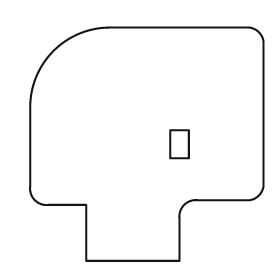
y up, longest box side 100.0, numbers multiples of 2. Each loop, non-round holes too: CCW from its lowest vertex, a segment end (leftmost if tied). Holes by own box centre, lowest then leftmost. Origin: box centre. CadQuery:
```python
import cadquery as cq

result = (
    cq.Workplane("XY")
    .moveTo(-26.0, -50.0)
    .lineTo(14.0, -50.0)
    .lineTo(14.0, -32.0)
    .threePointArc((16.0, -26.0), (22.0, -24.0))
    .lineTo(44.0, -24.0)
    .threePointArc((48.0, -22.0), (50.0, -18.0))
    .lineTo(50.0, 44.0)
    .threePointArc((48.0, 48.0), (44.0, 50.0))
    .lineTo(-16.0, 50.0)
    .threePointArc((-40.0, 40.0), (-50.0, 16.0))
    .lineTo(-50.0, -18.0)
    .threePointArc((-48.0, -24.0), (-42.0, -26.0))
    .lineTo(-26.0, -26.0)
    .close()
    .moveTo(10.0, -6.0)
    .lineTo(18.0, -6.0)
    .lineTo(18.0, 6.0)
    .lineTo(10.0, 6.0)
    .close()
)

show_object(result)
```